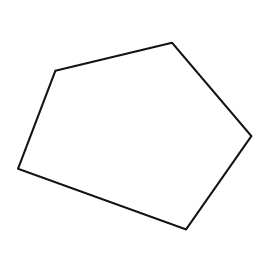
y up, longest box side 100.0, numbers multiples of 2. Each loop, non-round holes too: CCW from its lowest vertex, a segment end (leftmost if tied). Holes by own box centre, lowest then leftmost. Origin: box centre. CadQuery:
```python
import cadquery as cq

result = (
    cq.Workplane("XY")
    .moveTo(22.0, -40.0)
    .lineTo(50.0, 0.0)
    .lineTo(16.0, 40.0)
    .lineTo(-34.0, 28.0)
    .lineTo(-50.0, -14.0)
    .close()
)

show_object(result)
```